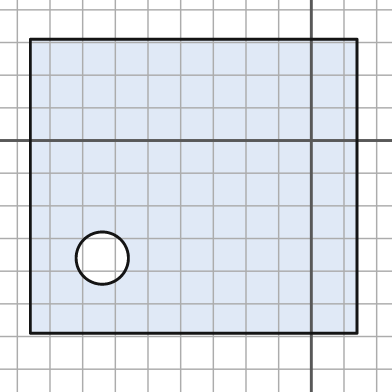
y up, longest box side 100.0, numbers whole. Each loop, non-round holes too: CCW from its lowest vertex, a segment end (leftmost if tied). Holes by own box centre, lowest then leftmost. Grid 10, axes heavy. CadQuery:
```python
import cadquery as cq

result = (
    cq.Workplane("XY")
    .moveTo(-86.0, -59.0)
    .lineTo(14.0, -59.0)
    .lineTo(14.0, 31.0)
    .lineTo(-86.0, 31.0)
    .close()
    .moveTo(-64.0, -36.0)
    .circle(8.0)
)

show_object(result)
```